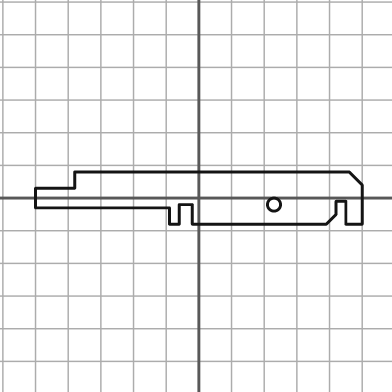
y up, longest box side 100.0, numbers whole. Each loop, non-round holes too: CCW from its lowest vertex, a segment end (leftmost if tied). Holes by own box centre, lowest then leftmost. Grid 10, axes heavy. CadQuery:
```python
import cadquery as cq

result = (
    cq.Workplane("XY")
    .moveTo(-9.0, -8.0)
    .lineTo(-6.0, -8.0)
    .lineTo(-6.0, -2.0)
    .lineTo(-2.0, -2.0)
    .lineTo(-2.0, -8.0)
    .lineTo(39.0, -8.0)
    .lineTo(42.0, -5.0)
    .lineTo(42.0, -1.0)
    .lineTo(45.0, -1.0)
    .lineTo(45.0, -8.0)
    .lineTo(50.0, -8.0)
    .lineTo(50.0, 4.0)
    .lineTo(46.0, 8.0)
    .lineTo(-38.0, 8.0)
    .lineTo(-38.0, 3.0)
    .lineTo(-50.0, 3.0)
    .lineTo(-50.0, -3.0)
    .lineTo(-9.0, -3.0)
    .close()
    .moveTo(23.0, -2.0)
    .circle(2.0)
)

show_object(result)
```